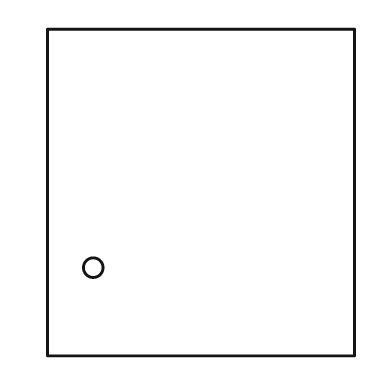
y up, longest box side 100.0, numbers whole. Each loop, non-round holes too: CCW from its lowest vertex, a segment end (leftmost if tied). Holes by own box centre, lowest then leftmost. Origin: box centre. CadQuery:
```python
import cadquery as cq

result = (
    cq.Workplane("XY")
    .moveTo(-47.0, -50.0)
    .lineTo(47.0, -50.0)
    .lineTo(47.0, 50.0)
    .lineTo(-47.0, 50.0)
    .close()
    .moveTo(-33.0, -23.0)
    .circle(3.0)
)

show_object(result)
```